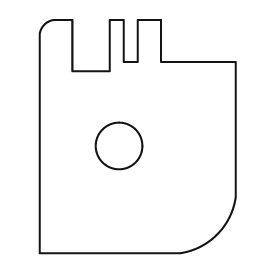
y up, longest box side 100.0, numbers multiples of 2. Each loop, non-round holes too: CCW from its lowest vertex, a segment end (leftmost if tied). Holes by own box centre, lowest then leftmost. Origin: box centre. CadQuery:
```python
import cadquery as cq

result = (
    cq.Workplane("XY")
    .moveTo(-42.0, -50.0)
    .lineTo(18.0, -50.0)
    .threePointArc((34.0, -42.0), (42.0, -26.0))
    .lineTo(42.0, 32.0)
    .lineTo(10.0, 32.0)
    .lineTo(10.0, 50.0)
    .lineTo(0.0, 50.0)
    .lineTo(0.0, 32.0)
    .lineTo(-6.0, 32.0)
    .lineTo(-6.0, 50.0)
    .lineTo(-12.0, 50.0)
    .lineTo(-12.0, 28.0)
    .lineTo(-28.0, 28.0)
    .lineTo(-28.0, 50.0)
    .lineTo(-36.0, 50.0)
    .threePointArc((-40.0, 48.0), (-42.0, 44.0))
    .close()
    .moveTo(-8.0, -4.0)
    .circle(10.0)
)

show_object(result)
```